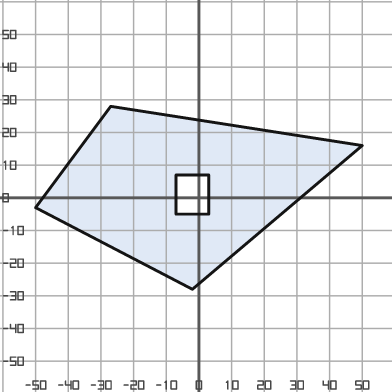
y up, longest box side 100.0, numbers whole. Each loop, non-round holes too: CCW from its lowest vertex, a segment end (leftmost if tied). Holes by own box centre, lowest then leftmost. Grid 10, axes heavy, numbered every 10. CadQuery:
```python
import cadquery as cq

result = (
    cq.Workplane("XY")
    .moveTo(-2.0, -28.0)
    .lineTo(50.0, 16.0)
    .lineTo(-27.0, 28.0)
    .lineTo(-50.0, -3.0)
    .close()
    .moveTo(-7.0, -5.0)
    .lineTo(3.0, -5.0)
    .lineTo(3.0, 7.0)
    .lineTo(-7.0, 7.0)
    .close()
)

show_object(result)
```